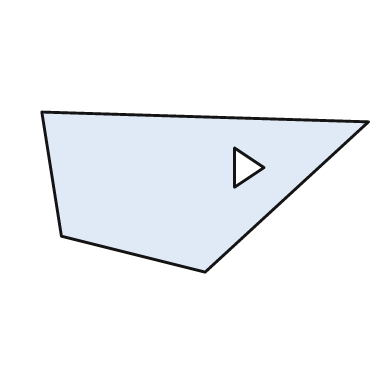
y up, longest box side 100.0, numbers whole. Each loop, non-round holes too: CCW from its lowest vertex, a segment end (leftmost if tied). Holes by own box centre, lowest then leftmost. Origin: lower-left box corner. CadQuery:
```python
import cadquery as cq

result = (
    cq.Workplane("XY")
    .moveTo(50.0, 0.0)
    .lineTo(100.0, 46.0)
    .lineTo(0.0, 49.0)
    .lineTo(6.0, 11.0)
    .close()
    .moveTo(59.0, 26.0)
    .lineTo(68.0, 32.0)
    .lineTo(59.0, 38.0)
    .close()
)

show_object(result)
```